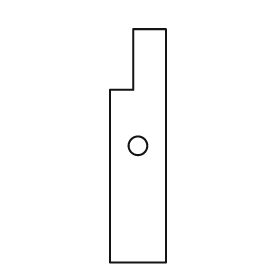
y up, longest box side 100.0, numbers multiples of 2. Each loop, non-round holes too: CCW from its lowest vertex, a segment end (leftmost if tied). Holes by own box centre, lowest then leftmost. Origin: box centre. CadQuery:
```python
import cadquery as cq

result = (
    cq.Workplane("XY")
    .moveTo(-12.0, -50.0)
    .lineTo(12.0, -50.0)
    .lineTo(12.0, 50.0)
    .lineTo(-2.0, 50.0)
    .lineTo(-2.0, 24.0)
    .lineTo(-12.0, 24.0)
    .close()
    .moveTo(0.0, 0.0)
    .circle(4.0)
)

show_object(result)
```